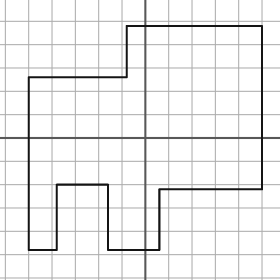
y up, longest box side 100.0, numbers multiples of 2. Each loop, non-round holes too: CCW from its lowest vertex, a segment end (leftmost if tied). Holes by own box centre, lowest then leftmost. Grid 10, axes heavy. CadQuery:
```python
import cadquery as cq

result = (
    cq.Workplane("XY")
    .moveTo(-50.0, -48.0)
    .lineTo(-38.0, -48.0)
    .lineTo(-38.0, -20.0)
    .lineTo(-16.0, -20.0)
    .lineTo(-16.0, -48.0)
    .lineTo(6.0, -48.0)
    .lineTo(6.0, -22.0)
    .lineTo(50.0, -22.0)
    .lineTo(50.0, 48.0)
    .lineTo(-8.0, 48.0)
    .lineTo(-8.0, 26.0)
    .lineTo(-50.0, 26.0)
    .close()
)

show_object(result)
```